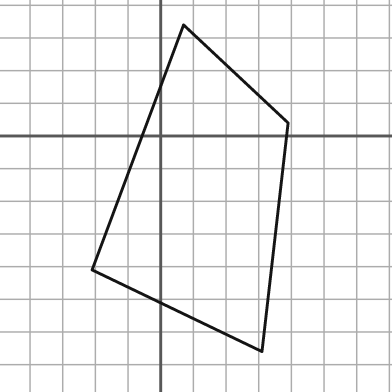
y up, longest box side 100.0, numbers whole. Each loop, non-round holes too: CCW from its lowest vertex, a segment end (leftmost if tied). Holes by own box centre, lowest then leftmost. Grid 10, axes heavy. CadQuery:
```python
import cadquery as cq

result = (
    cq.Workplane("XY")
    .moveTo(31.0, -66.0)
    .lineTo(39.0, 4.0)
    .lineTo(7.0, 34.0)
    .lineTo(-21.0, -41.0)
    .close()
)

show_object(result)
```